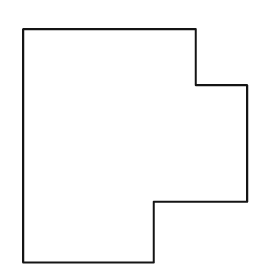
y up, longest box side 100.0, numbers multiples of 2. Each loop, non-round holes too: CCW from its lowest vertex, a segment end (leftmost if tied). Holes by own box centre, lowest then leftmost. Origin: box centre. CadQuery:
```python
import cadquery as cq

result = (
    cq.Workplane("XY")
    .moveTo(-48.0, -50.0)
    .lineTo(8.0, -50.0)
    .lineTo(8.0, -24.0)
    .lineTo(48.0, -24.0)
    .lineTo(48.0, 26.0)
    .lineTo(26.0, 26.0)
    .lineTo(26.0, 50.0)
    .lineTo(-48.0, 50.0)
    .close()
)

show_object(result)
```